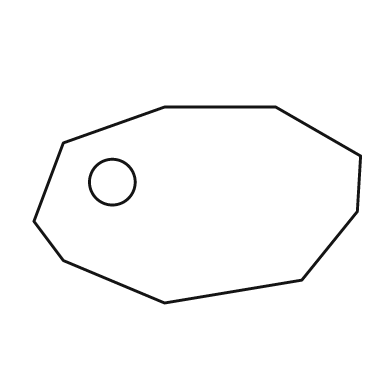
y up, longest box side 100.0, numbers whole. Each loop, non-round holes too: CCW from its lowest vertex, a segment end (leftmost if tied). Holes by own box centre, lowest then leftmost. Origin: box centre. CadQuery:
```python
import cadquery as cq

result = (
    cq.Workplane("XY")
    .moveTo(-10.0, -30.0)
    .lineTo(32.0, -23.0)
    .lineTo(49.0, -2.0)
    .lineTo(50.0, 15.0)
    .lineTo(24.0, 30.0)
    .lineTo(-10.0, 30.0)
    .lineTo(-41.0, 19.0)
    .lineTo(-50.0, -5.0)
    .lineTo(-41.0, -17.0)
    .close()
    .moveTo(-26.0, 7.0)
    .circle(7.0)
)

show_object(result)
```